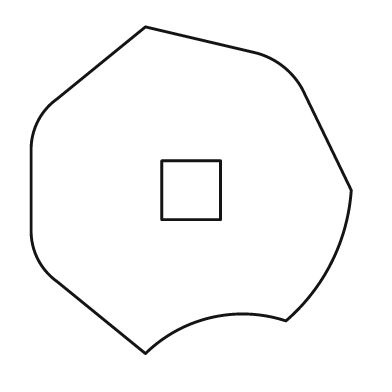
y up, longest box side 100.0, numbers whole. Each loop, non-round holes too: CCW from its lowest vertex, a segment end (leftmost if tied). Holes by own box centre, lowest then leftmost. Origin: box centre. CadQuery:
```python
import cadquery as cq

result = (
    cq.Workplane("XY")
    .moveTo(-14.0, -50.0)
    .threePointArc((6.0, -39.0), (29.0, -40.0))
    .threePointArc((43.0, -22.0), (49.0, 0.0))
    .lineTo(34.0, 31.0)
    .threePointArc((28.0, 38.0), (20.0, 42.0))
    .lineTo(-14.0, 50.0)
    .lineTo(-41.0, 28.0)
    .threePointArc((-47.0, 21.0), (-49.0, 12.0))
    .lineTo(-49.0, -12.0)
    .threePointArc((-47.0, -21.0), (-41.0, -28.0))
    .close()
    .moveTo(-9.0, -9.0)
    .lineTo(9.0, -9.0)
    .lineTo(9.0, 9.0)
    .lineTo(-9.0, 9.0)
    .close()
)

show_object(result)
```